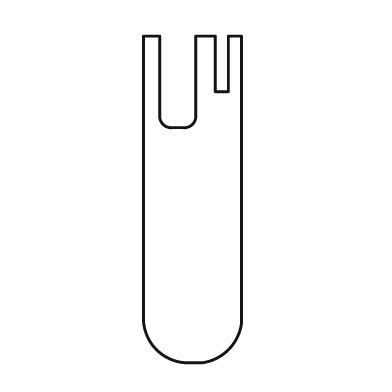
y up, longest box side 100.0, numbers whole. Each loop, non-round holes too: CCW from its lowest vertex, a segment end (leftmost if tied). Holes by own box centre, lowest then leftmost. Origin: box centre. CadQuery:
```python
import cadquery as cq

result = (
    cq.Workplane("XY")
    .moveTo(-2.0, -50.0)
    .lineTo(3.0, -50.0)
    .threePointArc((11.0, -46.0), (15.0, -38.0))
    .lineTo(15.0, 50.0)
    .lineTo(11.0, 50.0)
    .lineTo(11.0, 33.0)
    .lineTo(7.0, 33.0)
    .lineTo(7.0, 50.0)
    .lineTo(1.0, 50.0)
    .lineTo(1.0, 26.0)
    .threePointArc((0.0, 23.0), (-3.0, 22.0))
    .lineTo(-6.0, 22.0)
    .threePointArc((-9.0, 23.0), (-10.0, 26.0))
    .lineTo(-10.0, 50.0)
    .lineTo(-15.0, 50.0)
    .lineTo(-15.0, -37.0)
    .threePointArc((-11.0, -46.0), (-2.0, -50.0))
    .close()
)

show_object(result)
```